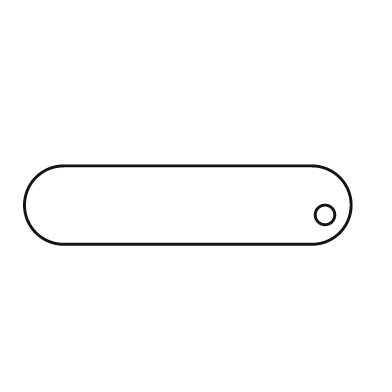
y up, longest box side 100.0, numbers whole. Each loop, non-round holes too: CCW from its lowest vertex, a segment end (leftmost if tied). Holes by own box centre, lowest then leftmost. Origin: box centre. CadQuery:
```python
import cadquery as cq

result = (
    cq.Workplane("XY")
    .moveTo(-38.0, -12.0)
    .lineTo(38.0, -12.0)
    .threePointArc((50.0, 0.0), (38.0, 12.0))
    .lineTo(-38.0, 12.0)
    .threePointArc((-50.0, 0.0), (-38.0, -12.0))
    .close()
    .moveTo(42.0, -3.0)
    .circle(3.0)
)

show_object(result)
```